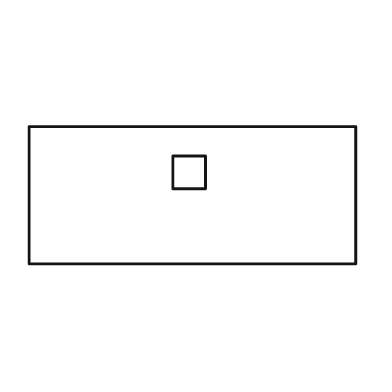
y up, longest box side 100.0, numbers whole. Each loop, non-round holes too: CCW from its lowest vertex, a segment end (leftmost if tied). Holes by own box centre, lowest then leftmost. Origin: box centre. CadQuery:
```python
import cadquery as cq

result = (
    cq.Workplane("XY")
    .moveTo(-50.0, -21.0)
    .lineTo(50.0, -21.0)
    .lineTo(50.0, 21.0)
    .lineTo(-50.0, 21.0)
    .close()
    .moveTo(-6.0, 2.0)
    .lineTo(4.0, 2.0)
    .lineTo(4.0, 12.0)
    .lineTo(-6.0, 12.0)
    .close()
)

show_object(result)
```